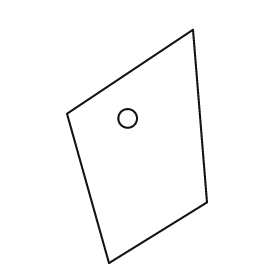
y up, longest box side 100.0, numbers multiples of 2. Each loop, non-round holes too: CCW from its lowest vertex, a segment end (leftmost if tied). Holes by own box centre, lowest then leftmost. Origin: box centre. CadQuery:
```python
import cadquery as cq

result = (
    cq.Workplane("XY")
    .moveTo(-12.0, -50.0)
    .lineTo(30.0, -24.0)
    .lineTo(24.0, 50.0)
    .lineTo(-30.0, 14.0)
    .close()
    .moveTo(-4.0, 12.0)
    .circle(4.0)
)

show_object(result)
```